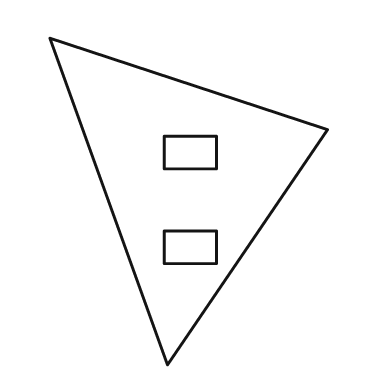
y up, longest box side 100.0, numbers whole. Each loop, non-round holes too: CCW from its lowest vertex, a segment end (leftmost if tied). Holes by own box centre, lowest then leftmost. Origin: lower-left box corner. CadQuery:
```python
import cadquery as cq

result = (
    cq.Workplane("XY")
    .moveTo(36.0, 0.0)
    .lineTo(85.0, 72.0)
    .lineTo(0.0, 100.0)
    .close()
    .moveTo(35.0, 31.0)
    .lineTo(51.0, 31.0)
    .lineTo(51.0, 41.0)
    .lineTo(35.0, 41.0)
    .close()
    .moveTo(35.0, 60.0)
    .lineTo(51.0, 60.0)
    .lineTo(51.0, 70.0)
    .lineTo(35.0, 70.0)
    .close()
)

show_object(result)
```